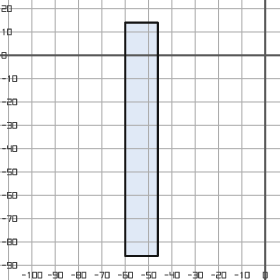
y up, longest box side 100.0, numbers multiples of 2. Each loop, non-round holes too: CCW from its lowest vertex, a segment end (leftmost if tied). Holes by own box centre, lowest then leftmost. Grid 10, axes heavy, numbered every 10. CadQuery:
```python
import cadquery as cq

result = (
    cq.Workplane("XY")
    .moveTo(-60.0, -86.0)
    .lineTo(-46.0, -86.0)
    .lineTo(-46.0, 14.0)
    .lineTo(-60.0, 14.0)
    .close()
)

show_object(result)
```